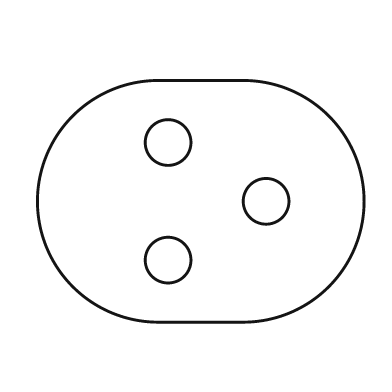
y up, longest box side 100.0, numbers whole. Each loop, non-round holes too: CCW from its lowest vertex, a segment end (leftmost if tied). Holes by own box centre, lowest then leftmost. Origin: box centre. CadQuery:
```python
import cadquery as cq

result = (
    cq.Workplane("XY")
    .moveTo(-13.0, -37.0)
    .lineTo(13.0, -37.0)
    .threePointArc((50.0, 0.0), (13.0, 37.0))
    .lineTo(-13.0, 37.0)
    .threePointArc((-50.0, 0.0), (-13.0, -37.0))
    .close()
    .moveTo(-10.0, -18.0)
    .circle(7.0)
    .moveTo(20.0, 0.0)
    .circle(7.0)
    .moveTo(-10.0, 18.0)
    .circle(7.0)
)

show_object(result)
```